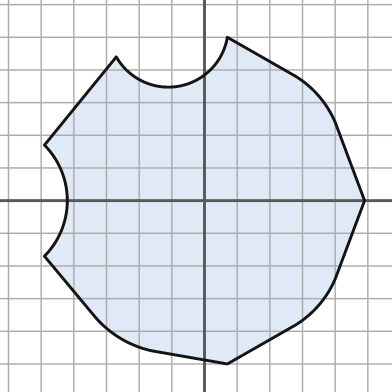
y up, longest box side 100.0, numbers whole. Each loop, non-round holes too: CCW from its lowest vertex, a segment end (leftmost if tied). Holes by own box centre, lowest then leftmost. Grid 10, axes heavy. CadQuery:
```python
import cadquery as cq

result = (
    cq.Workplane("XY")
    .moveTo(7.0, -50.0)
    .lineTo(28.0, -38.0)
    .threePointArc((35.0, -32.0), (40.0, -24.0))
    .lineTo(49.0, 0.0)
    .lineTo(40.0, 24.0)
    .threePointArc((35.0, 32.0), (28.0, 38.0))
    .lineTo(7.0, 50.0)
    .threePointArc((-8.0, 35.0), (-27.0, 44.0))
    .lineTo(-49.0, 17.0)
    .threePointArc((-42.0, 0.0), (-49.0, -17.0))
    .lineTo(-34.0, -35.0)
    .threePointArc((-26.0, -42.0), (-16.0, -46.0))
    .close()
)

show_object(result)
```